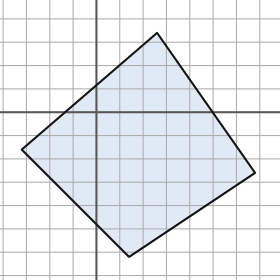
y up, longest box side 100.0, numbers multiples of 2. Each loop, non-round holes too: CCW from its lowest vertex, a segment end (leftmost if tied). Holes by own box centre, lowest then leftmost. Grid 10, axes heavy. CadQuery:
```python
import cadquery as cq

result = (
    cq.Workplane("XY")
    .moveTo(14.0, -62.0)
    .lineTo(68.0, -26.0)
    .lineTo(26.0, 34.0)
    .lineTo(-32.0, -16.0)
    .close()
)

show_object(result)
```